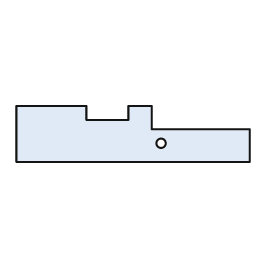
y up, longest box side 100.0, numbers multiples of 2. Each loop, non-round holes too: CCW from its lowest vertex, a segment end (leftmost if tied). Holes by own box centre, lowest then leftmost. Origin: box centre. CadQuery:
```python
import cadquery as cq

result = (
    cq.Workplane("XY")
    .moveTo(-50.0, -12.0)
    .lineTo(50.0, -12.0)
    .lineTo(50.0, 2.0)
    .lineTo(8.0, 2.0)
    .lineTo(8.0, 12.0)
    .lineTo(-2.0, 12.0)
    .lineTo(-2.0, 6.0)
    .lineTo(-20.0, 6.0)
    .lineTo(-20.0, 12.0)
    .lineTo(-50.0, 12.0)
    .close()
    .moveTo(12.0, -4.0)
    .circle(2.0)
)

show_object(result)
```